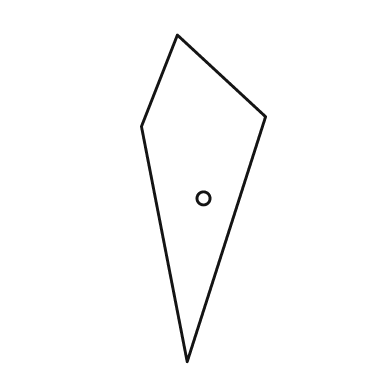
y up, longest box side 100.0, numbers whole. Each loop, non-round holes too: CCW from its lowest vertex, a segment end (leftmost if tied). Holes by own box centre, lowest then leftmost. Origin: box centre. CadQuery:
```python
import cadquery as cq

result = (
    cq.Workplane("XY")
    .moveTo(-5.0, -50.0)
    .lineTo(19.0, 25.0)
    .lineTo(-8.0, 50.0)
    .lineTo(-19.0, 22.0)
    .close()
    .moveTo(0.0, 0.0)
    .circle(2.0)
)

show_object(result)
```